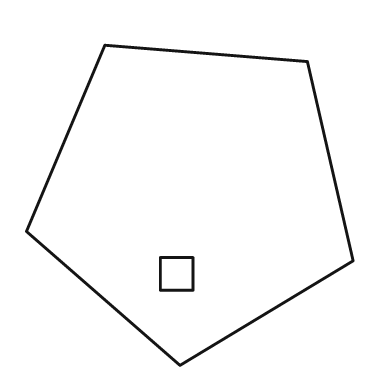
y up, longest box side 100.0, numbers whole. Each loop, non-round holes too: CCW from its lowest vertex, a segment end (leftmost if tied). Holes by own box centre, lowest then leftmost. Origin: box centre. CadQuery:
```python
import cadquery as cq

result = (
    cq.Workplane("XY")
    .moveTo(-3.0, -49.0)
    .lineTo(50.0, -17.0)
    .lineTo(36.0, 44.0)
    .lineTo(-26.0, 49.0)
    .lineTo(-50.0, -8.0)
    .close()
    .moveTo(-9.0, -26.0)
    .lineTo(1.0, -26.0)
    .lineTo(1.0, -16.0)
    .lineTo(-9.0, -16.0)
    .close()
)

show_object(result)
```